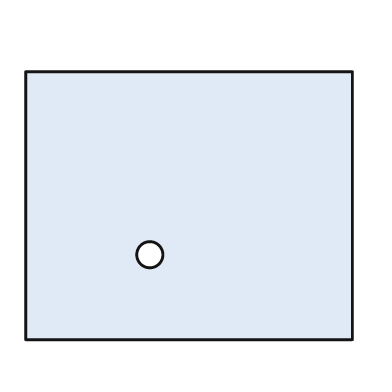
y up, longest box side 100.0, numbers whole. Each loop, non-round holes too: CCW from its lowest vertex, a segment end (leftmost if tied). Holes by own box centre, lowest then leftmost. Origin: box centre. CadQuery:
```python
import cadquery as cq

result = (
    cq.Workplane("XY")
    .moveTo(-50.0, -41.0)
    .lineTo(50.0, -41.0)
    .lineTo(50.0, 41.0)
    .lineTo(-50.0, 41.0)
    .close()
    .moveTo(-12.0, -15.0)
    .circle(4.0)
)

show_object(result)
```